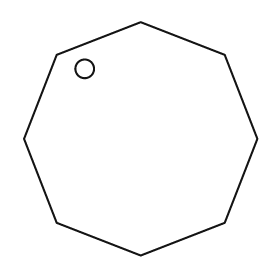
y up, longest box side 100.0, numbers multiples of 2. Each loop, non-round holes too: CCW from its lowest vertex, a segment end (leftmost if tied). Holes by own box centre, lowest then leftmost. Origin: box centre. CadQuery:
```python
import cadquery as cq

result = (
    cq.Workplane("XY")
    .moveTo(0.0, -50.0)
    .lineTo(36.0, -36.0)
    .lineTo(50.0, 0.0)
    .lineTo(36.0, 36.0)
    .lineTo(0.0, 50.0)
    .lineTo(-36.0, 36.0)
    .lineTo(-50.0, 0.0)
    .lineTo(-36.0, -36.0)
    .close()
    .moveTo(-24.0, 30.0)
    .circle(4.0)
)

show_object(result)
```